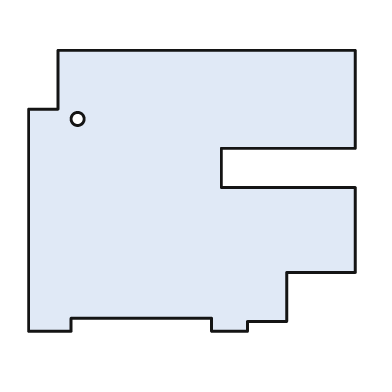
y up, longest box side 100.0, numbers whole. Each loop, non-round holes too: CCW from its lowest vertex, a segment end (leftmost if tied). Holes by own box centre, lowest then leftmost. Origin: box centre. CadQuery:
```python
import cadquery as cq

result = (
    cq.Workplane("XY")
    .moveTo(-50.0, -43.0)
    .lineTo(-37.0, -43.0)
    .lineTo(-37.0, -39.0)
    .lineTo(6.0, -39.0)
    .lineTo(6.0, -43.0)
    .lineTo(17.0, -43.0)
    .lineTo(17.0, -40.0)
    .lineTo(29.0, -40.0)
    .lineTo(29.0, -25.0)
    .lineTo(50.0, -25.0)
    .lineTo(50.0, 1.0)
    .lineTo(9.0, 1.0)
    .lineTo(9.0, 13.0)
    .lineTo(50.0, 13.0)
    .lineTo(50.0, 43.0)
    .lineTo(-41.0, 43.0)
    .lineTo(-41.0, 25.0)
    .lineTo(-50.0, 25.0)
    .close()
    .moveTo(-35.0, 22.0)
    .circle(2.0)
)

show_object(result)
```